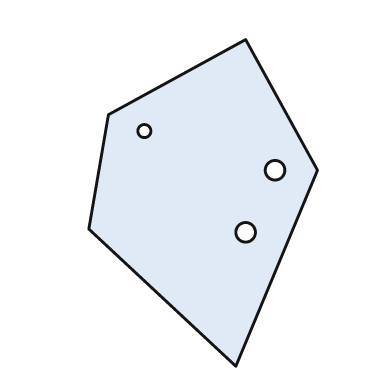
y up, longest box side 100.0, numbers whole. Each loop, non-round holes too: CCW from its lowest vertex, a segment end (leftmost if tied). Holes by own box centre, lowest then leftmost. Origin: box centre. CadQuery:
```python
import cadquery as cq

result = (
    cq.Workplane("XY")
    .moveTo(10.0, -50.0)
    .lineTo(35.0, 10.0)
    .lineTo(13.0, 50.0)
    .lineTo(-29.0, 27.0)
    .lineTo(-35.0, -8.0)
    .close()
    .moveTo(13.0, -9.0)
    .circle(3.0)
    .moveTo(22.0, 10.0)
    .circle(3.0)
    .moveTo(-18.0, 22.0)
    .circle(2.0)
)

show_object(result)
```